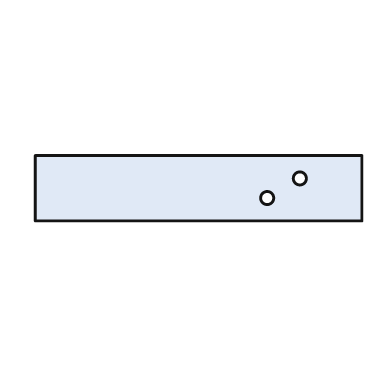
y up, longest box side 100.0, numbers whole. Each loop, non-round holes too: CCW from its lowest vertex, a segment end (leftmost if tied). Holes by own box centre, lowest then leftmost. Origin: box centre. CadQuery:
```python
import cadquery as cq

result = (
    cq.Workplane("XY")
    .moveTo(-50.0, -10.0)
    .lineTo(50.0, -10.0)
    .lineTo(50.0, 10.0)
    .lineTo(-50.0, 10.0)
    .close()
    .moveTo(21.0, -3.0)
    .circle(2.0)
    .moveTo(31.0, 3.0)
    .circle(2.0)
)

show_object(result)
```